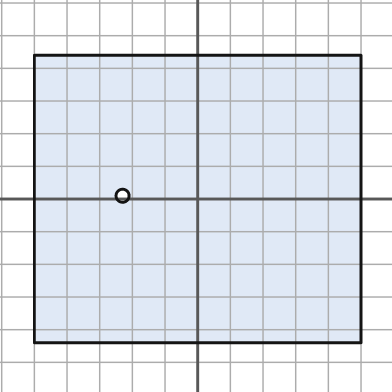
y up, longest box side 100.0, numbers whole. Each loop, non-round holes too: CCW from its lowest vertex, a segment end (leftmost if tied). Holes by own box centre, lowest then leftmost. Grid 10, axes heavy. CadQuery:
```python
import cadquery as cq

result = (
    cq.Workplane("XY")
    .moveTo(-50.0, -44.0)
    .lineTo(50.0, -44.0)
    .lineTo(50.0, 44.0)
    .lineTo(-50.0, 44.0)
    .close()
    .moveTo(-23.0, 1.0)
    .circle(2.0)
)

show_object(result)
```